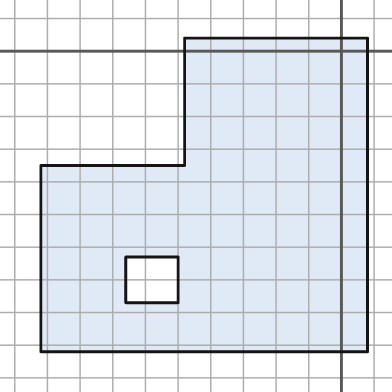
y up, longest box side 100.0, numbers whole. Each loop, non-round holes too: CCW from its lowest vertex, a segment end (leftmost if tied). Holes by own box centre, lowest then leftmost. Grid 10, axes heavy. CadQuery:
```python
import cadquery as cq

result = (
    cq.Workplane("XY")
    .moveTo(-92.0, -92.0)
    .lineTo(8.0, -92.0)
    .lineTo(8.0, 4.0)
    .lineTo(-48.0, 4.0)
    .lineTo(-48.0, -35.0)
    .lineTo(-92.0, -35.0)
    .close()
    .moveTo(-66.0, -77.0)
    .lineTo(-50.0, -77.0)
    .lineTo(-50.0, -63.0)
    .lineTo(-66.0, -63.0)
    .close()
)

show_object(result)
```